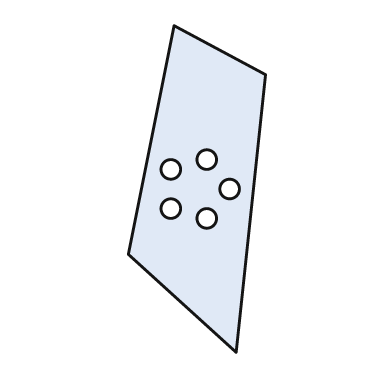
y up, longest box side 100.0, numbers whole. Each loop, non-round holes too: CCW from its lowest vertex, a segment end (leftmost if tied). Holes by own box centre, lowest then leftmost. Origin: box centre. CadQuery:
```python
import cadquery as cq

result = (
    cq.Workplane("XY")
    .moveTo(12.0, -50.0)
    .lineTo(21.0, 35.0)
    .lineTo(-7.0, 50.0)
    .lineTo(-21.0, -20.0)
    .close()
    .moveTo(3.0, -9.0)
    .circle(3.0)
    .moveTo(-8.0, -6.0)
    .circle(3.0)
    .moveTo(10.0, 0.0)
    .circle(3.0)
    .moveTo(-8.0, 6.0)
    .circle(3.0)
    .moveTo(3.0, 9.0)
    .circle(3.0)
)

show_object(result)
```